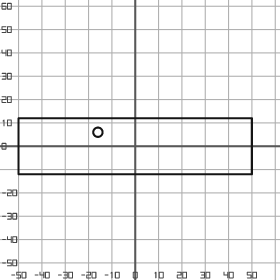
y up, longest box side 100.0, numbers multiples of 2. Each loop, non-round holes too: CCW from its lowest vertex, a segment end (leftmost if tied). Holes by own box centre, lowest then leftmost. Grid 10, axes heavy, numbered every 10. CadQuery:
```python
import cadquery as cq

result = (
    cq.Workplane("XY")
    .moveTo(-50.0, -12.0)
    .lineTo(50.0, -12.0)
    .lineTo(50.0, 12.0)
    .lineTo(-50.0, 12.0)
    .close()
    .moveTo(-16.0, 6.0)
    .circle(2.0)
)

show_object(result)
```